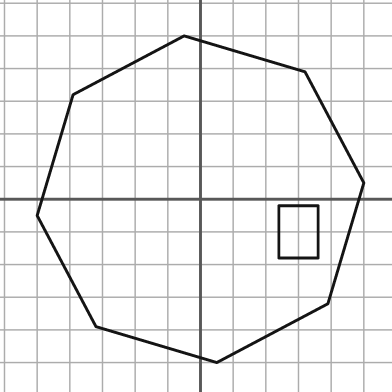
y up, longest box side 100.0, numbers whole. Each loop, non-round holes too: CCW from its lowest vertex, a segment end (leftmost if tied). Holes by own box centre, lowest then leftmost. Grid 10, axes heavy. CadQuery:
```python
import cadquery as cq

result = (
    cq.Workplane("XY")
    .moveTo(5.0, -50.0)
    .lineTo(39.0, -32.0)
    .lineTo(50.0, 5.0)
    .lineTo(32.0, 39.0)
    .lineTo(-5.0, 50.0)
    .lineTo(-39.0, 32.0)
    .lineTo(-50.0, -5.0)
    .lineTo(-32.0, -39.0)
    .close()
    .moveTo(24.0, -18.0)
    .lineTo(36.0, -18.0)
    .lineTo(36.0, -2.0)
    .lineTo(24.0, -2.0)
    .close()
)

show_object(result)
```